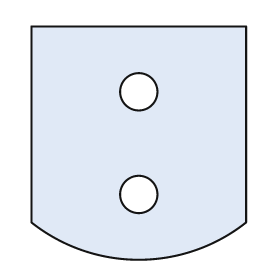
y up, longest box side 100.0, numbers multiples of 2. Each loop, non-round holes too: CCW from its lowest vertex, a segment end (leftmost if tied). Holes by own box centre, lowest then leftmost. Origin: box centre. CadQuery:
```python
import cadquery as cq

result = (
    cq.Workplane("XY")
    .moveTo(-46.0, -34.0)
    .threePointArc((0.0, -50.0), (46.0, -34.0))
    .lineTo(46.0, 50.0)
    .lineTo(-46.0, 50.0)
    .close()
    .moveTo(0.0, -22.0)
    .circle(8.0)
    .moveTo(0.0, 22.0)
    .circle(8.0)
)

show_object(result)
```